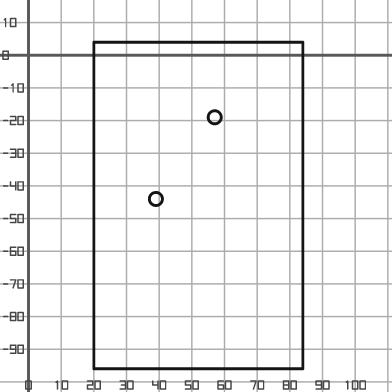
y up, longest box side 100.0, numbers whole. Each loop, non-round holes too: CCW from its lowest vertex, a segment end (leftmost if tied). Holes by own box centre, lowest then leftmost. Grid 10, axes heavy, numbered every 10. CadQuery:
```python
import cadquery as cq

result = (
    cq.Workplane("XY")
    .moveTo(20.0, -96.0)
    .lineTo(84.0, -96.0)
    .lineTo(84.0, 4.0)
    .lineTo(20.0, 4.0)
    .close()
    .moveTo(39.0, -44.0)
    .circle(2.0)
    .moveTo(57.0, -19.0)
    .circle(2.0)
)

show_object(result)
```